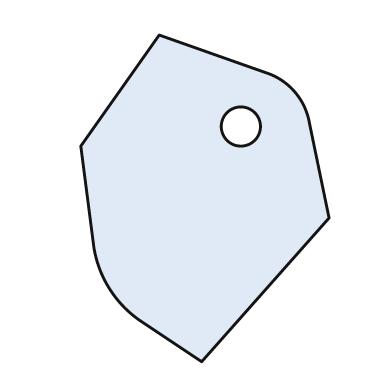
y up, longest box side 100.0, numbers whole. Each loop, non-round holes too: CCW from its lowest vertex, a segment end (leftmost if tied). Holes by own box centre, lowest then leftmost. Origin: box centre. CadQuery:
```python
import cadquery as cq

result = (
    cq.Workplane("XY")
    .moveTo(-1.0, -50.0)
    .lineTo(38.0, -6.0)
    .lineTo(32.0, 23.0)
    .threePointArc((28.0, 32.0), (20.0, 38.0))
    .lineTo(-14.0, 50.0)
    .lineTo(-38.0, 16.0)
    .lineTo(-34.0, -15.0)
    .threePointArc((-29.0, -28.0), (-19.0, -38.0))
    .close()
    .moveTo(11.0, 22.0)
    .circle(6.0)
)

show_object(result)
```